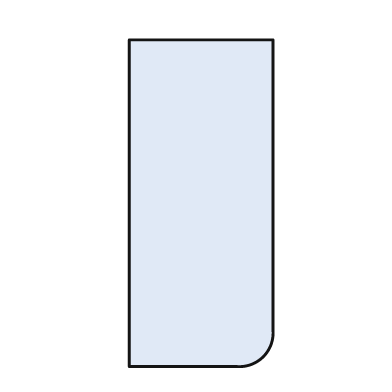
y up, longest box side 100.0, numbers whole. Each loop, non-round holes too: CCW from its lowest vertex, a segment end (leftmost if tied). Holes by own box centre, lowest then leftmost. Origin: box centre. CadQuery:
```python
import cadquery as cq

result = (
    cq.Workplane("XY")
    .moveTo(-22.0, -50.0)
    .lineTo(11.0, -50.0)
    .threePointArc((19.0, -47.0), (22.0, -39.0))
    .lineTo(22.0, 50.0)
    .lineTo(-22.0, 50.0)
    .close()
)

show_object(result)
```